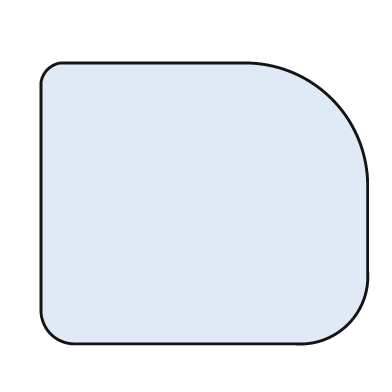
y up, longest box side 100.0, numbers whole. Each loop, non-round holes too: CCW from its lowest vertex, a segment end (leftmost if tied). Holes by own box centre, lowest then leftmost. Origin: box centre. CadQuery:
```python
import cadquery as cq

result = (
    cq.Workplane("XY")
    .moveTo(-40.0, -43.0)
    .lineTo(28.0, -43.0)
    .threePointArc((44.0, -37.0), (50.0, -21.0))
    .lineTo(50.0, 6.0)
    .threePointArc((39.0, 32.0), (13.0, 43.0))
    .lineTo(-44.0, 43.0)
    .threePointArc((-48.0, 41.0), (-50.0, 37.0))
    .lineTo(-50.0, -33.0)
    .threePointArc((-47.0, -40.0), (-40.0, -43.0))
    .close()
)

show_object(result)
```